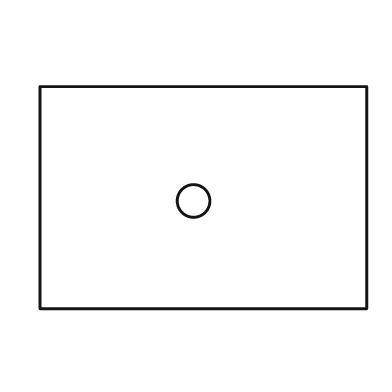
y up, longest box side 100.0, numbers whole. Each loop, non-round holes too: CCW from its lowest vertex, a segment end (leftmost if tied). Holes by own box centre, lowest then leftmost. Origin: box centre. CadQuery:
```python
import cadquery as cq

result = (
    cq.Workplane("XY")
    .moveTo(-50.0, -34.0)
    .lineTo(50.0, -34.0)
    .lineTo(50.0, 34.0)
    .lineTo(-50.0, 34.0)
    .close()
    .moveTo(-3.0, -1.0)
    .circle(5.0)
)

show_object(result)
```